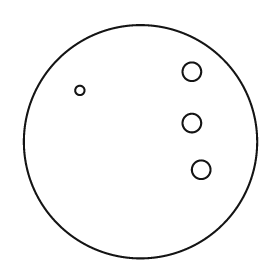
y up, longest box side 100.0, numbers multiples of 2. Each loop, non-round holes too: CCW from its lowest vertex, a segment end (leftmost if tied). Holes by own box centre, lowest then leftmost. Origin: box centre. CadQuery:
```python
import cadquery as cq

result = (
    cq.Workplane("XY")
    .moveTo(0.0, 0.0)
    .circle(50.0)
    .moveTo(26.0, -12.0)
    .circle(4.0)
    .moveTo(22.0, 8.0)
    .circle(4.0)
    .moveTo(-26.0, 22.0)
    .circle(2.0)
    .moveTo(22.0, 30.0)
    .circle(4.0)
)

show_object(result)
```